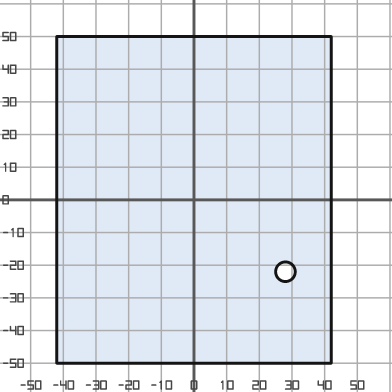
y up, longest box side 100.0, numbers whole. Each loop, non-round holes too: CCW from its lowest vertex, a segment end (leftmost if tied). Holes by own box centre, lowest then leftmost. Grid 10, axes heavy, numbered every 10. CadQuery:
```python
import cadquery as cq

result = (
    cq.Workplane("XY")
    .moveTo(-42.0, -50.0)
    .lineTo(42.0, -50.0)
    .lineTo(42.0, 50.0)
    .lineTo(-42.0, 50.0)
    .close()
    .moveTo(28.0, -22.0)
    .circle(3.0)
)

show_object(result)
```